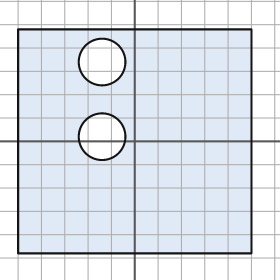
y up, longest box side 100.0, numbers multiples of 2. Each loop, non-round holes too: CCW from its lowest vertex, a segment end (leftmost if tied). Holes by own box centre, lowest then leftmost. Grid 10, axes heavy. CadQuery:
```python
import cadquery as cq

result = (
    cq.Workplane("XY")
    .moveTo(-50.0, -48.0)
    .lineTo(50.0, -48.0)
    .lineTo(50.0, 48.0)
    .lineTo(-50.0, 48.0)
    .close()
    .moveTo(-14.0, 2.0)
    .circle(10.0)
    .moveTo(-14.0, 34.0)
    .circle(10.0)
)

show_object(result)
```